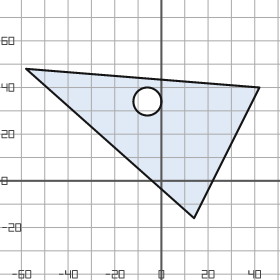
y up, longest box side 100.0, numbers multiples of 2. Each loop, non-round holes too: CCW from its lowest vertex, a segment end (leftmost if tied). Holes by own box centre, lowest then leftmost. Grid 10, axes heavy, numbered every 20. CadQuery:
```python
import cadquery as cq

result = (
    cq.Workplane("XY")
    .moveTo(14.0, -16.0)
    .lineTo(42.0, 40.0)
    .lineTo(-58.0, 48.0)
    .close()
    .moveTo(-6.0, 34.0)
    .circle(6.0)
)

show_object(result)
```